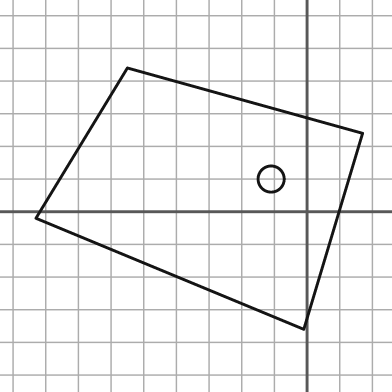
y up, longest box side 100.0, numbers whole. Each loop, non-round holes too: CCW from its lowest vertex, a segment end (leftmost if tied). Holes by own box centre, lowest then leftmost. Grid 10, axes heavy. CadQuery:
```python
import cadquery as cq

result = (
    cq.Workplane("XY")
    .moveTo(-1.0, -36.0)
    .lineTo(17.0, 24.0)
    .lineTo(-55.0, 44.0)
    .lineTo(-83.0, -2.0)
    .close()
    .moveTo(-11.0, 10.0)
    .circle(4.0)
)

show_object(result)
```